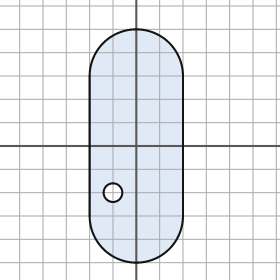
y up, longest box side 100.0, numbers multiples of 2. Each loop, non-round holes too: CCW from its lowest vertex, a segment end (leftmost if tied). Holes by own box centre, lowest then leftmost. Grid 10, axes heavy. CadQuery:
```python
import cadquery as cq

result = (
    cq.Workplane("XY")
    .moveTo(-20.0, -30.0)
    .threePointArc((0.0, -50.0), (20.0, -30.0))
    .lineTo(20.0, 30.0)
    .threePointArc((0.0, 50.0), (-20.0, 30.0))
    .close()
    .moveTo(-10.0, -20.0)
    .circle(4.0)
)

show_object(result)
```